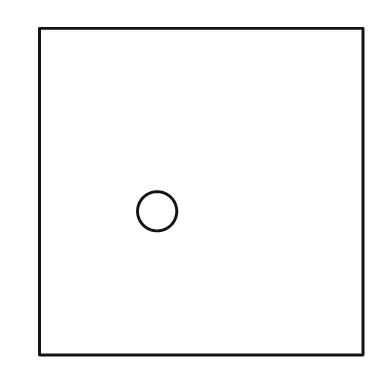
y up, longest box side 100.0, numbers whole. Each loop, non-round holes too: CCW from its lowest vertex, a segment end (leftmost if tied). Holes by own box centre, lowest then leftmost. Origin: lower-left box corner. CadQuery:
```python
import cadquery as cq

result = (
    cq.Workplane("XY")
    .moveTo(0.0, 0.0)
    .lineTo(99.0, 0.0)
    .lineTo(99.0, 100.0)
    .lineTo(0.0, 100.0)
    .close()
    .moveTo(36.0, 44.0)
    .circle(6.0)
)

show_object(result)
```